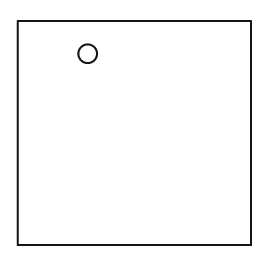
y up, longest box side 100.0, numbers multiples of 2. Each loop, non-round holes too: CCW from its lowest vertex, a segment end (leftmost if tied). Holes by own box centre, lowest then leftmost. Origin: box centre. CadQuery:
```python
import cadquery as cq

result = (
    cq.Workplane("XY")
    .moveTo(-50.0, -48.0)
    .lineTo(50.0, -48.0)
    .lineTo(50.0, 48.0)
    .lineTo(-50.0, 48.0)
    .close()
    .moveTo(-20.0, 34.0)
    .circle(4.0)
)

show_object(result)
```